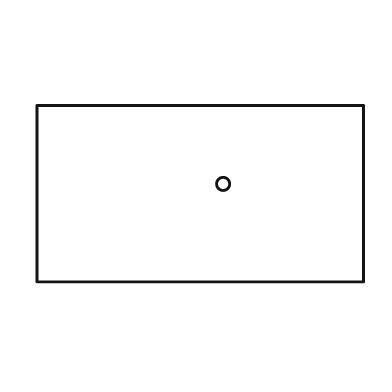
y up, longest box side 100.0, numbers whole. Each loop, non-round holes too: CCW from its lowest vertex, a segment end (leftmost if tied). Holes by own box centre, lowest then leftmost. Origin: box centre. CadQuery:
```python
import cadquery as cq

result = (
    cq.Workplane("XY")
    .moveTo(-50.0, -27.0)
    .lineTo(50.0, -27.0)
    .lineTo(50.0, 27.0)
    .lineTo(-50.0, 27.0)
    .close()
    .moveTo(7.0, 3.0)
    .circle(2.0)
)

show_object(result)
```